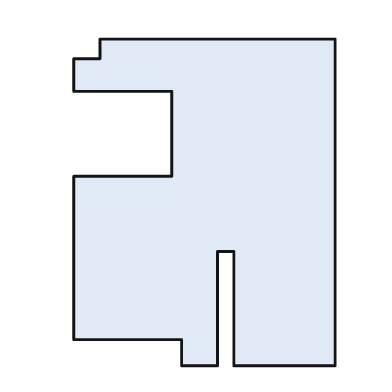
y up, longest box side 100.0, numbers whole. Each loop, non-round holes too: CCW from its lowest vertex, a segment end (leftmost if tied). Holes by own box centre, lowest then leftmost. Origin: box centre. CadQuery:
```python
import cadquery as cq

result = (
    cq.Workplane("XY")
    .moveTo(-7.0, -50.0)
    .lineTo(4.0, -50.0)
    .lineTo(4.0, -15.0)
    .lineTo(9.0, -15.0)
    .lineTo(9.0, -50.0)
    .lineTo(40.0, -50.0)
    .lineTo(40.0, 50.0)
    .lineTo(-32.0, 50.0)
    .lineTo(-32.0, 44.0)
    .lineTo(-40.0, 44.0)
    .lineTo(-40.0, 34.0)
    .lineTo(-10.0, 34.0)
    .lineTo(-10.0, 8.0)
    .lineTo(-40.0, 8.0)
    .lineTo(-40.0, -42.0)
    .lineTo(-7.0, -42.0)
    .close()
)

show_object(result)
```